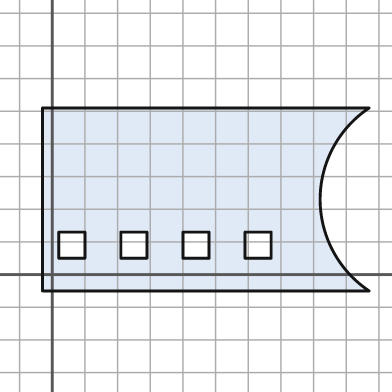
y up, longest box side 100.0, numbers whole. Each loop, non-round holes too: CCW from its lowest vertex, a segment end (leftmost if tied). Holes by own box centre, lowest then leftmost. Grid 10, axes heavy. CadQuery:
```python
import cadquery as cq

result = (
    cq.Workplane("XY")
    .moveTo(-3.0, -5.0)
    .lineTo(97.0, -5.0)
    .threePointArc((82.0, 23.0), (97.0, 51.0))
    .lineTo(-3.0, 51.0)
    .close()
    .moveTo(2.0, 5.0)
    .lineTo(10.0, 5.0)
    .lineTo(10.0, 13.0)
    .lineTo(2.0, 13.0)
    .close()
    .moveTo(21.0, 5.0)
    .lineTo(29.0, 5.0)
    .lineTo(29.0, 13.0)
    .lineTo(21.0, 13.0)
    .close()
    .moveTo(40.0, 5.0)
    .lineTo(48.0, 5.0)
    .lineTo(48.0, 13.0)
    .lineTo(40.0, 13.0)
    .close()
    .moveTo(59.0, 5.0)
    .lineTo(67.0, 5.0)
    .lineTo(67.0, 13.0)
    .lineTo(59.0, 13.0)
    .close()
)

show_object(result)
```